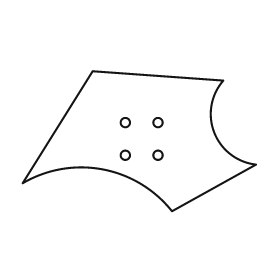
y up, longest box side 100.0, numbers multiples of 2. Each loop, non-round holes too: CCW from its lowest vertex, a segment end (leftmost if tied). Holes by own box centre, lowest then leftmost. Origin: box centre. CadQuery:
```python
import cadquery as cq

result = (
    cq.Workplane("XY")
    .moveTo(14.0, -30.0)
    .lineTo(50.0, -10.0)
    .threePointArc((32.0, 4.0), (36.0, 26.0))
    .lineTo(-20.0, 30.0)
    .lineTo(-50.0, -18.0)
    .threePointArc((-16.0, -12.0), (14.0, -30.0))
    .close()
    .moveTo(-6.0, -6.0)
    .circle(2.0)
    .moveTo(8.0, -6.0)
    .circle(2.0)
    .moveTo(-6.0, 8.0)
    .circle(2.0)
    .moveTo(8.0, 8.0)
    .circle(2.0)
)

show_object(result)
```